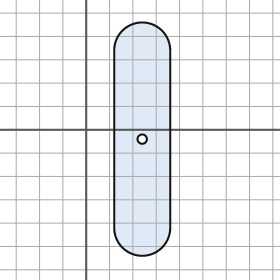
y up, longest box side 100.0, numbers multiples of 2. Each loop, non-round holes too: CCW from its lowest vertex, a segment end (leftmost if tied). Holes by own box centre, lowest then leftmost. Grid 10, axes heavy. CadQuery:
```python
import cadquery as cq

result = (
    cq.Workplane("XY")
    .moveTo(12.0, -42.0)
    .threePointArc((24.0, -54.0), (36.0, -42.0))
    .lineTo(36.0, 34.0)
    .threePointArc((24.0, 46.0), (12.0, 34.0))
    .close()
    .moveTo(24.0, -4.0)
    .circle(2.0)
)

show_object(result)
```